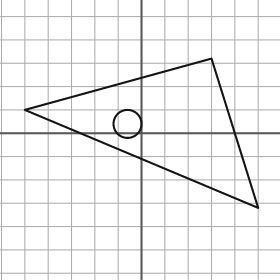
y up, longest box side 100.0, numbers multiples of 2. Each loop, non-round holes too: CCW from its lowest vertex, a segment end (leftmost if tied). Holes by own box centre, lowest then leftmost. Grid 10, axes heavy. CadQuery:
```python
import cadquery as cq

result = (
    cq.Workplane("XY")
    .moveTo(50.0, -32.0)
    .lineTo(30.0, 32.0)
    .lineTo(-50.0, 10.0)
    .close()
    .moveTo(-6.0, 4.0)
    .circle(6.0)
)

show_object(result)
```